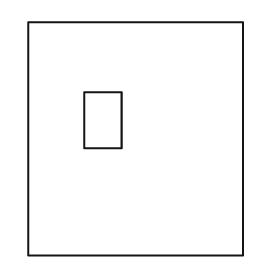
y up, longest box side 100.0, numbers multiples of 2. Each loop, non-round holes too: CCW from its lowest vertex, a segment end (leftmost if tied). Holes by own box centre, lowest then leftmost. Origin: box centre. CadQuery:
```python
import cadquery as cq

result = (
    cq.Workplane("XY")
    .moveTo(-46.0, -50.0)
    .lineTo(46.0, -50.0)
    .lineTo(46.0, 50.0)
    .lineTo(-46.0, 50.0)
    .close()
    .moveTo(-22.0, -4.0)
    .lineTo(-6.0, -4.0)
    .lineTo(-6.0, 20.0)
    .lineTo(-22.0, 20.0)
    .close()
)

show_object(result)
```